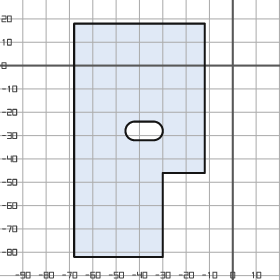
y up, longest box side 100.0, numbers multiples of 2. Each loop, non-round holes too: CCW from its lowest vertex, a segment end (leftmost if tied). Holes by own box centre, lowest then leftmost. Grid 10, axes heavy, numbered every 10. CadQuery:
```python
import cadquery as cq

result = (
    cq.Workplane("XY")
    .moveTo(-68.0, -82.0)
    .lineTo(-30.0, -82.0)
    .lineTo(-30.0, -46.0)
    .lineTo(-12.0, -46.0)
    .lineTo(-12.0, 18.0)
    .lineTo(-68.0, 18.0)
    .close()
    .moveTo(-42.0, -32.0)
    .lineTo(-34.0, -32.0)
    .threePointArc((-30.0, -28.0), (-34.0, -24.0))
    .lineTo(-42.0, -24.0)
    .threePointArc((-46.0, -28.0), (-42.0, -32.0))
    .close()
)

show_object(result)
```